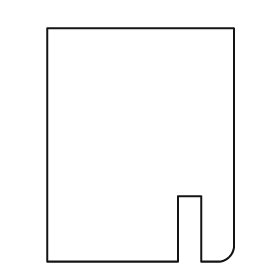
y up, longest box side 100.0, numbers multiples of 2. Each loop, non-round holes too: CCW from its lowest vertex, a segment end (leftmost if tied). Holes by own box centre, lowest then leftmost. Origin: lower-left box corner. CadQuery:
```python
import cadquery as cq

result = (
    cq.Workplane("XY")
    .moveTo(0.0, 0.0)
    .lineTo(56.0, 0.0)
    .lineTo(56.0, 28.0)
    .lineTo(66.0, 28.0)
    .lineTo(66.0, 0.0)
    .lineTo(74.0, 0.0)
    .threePointArc((78.0, 2.0), (80.0, 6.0))
    .lineTo(80.0, 100.0)
    .lineTo(0.0, 100.0)
    .close()
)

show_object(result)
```